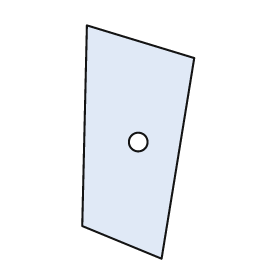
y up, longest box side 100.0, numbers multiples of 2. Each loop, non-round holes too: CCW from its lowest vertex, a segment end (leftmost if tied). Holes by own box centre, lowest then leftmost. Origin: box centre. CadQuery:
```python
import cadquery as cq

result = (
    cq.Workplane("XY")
    .moveTo(10.0, -50.0)
    .lineTo(24.0, 36.0)
    .lineTo(-22.0, 50.0)
    .lineTo(-24.0, -36.0)
    .close()
    .moveTo(0.0, 0.0)
    .circle(4.0)
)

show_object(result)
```